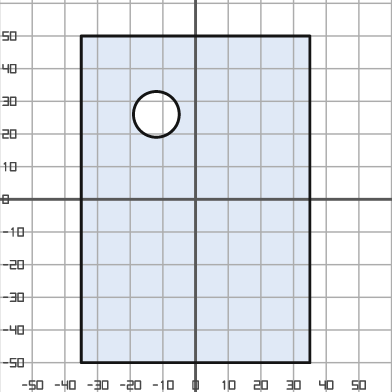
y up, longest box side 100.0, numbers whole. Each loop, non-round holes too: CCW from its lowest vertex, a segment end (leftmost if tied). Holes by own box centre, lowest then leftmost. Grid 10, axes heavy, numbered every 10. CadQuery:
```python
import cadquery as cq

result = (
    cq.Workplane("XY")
    .moveTo(-35.0, -50.0)
    .lineTo(35.0, -50.0)
    .lineTo(35.0, 50.0)
    .lineTo(-35.0, 50.0)
    .close()
    .moveTo(-12.0, 26.0)
    .circle(7.0)
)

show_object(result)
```